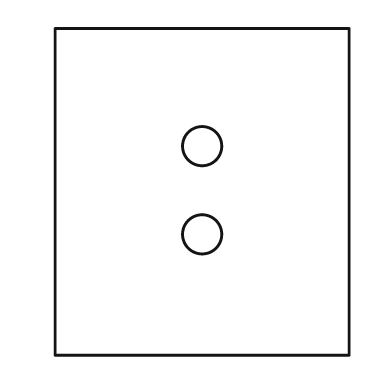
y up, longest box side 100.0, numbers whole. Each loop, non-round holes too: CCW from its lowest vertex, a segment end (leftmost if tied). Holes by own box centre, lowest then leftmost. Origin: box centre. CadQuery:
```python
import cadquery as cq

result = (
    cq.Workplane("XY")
    .moveTo(-45.0, -50.0)
    .lineTo(45.0, -50.0)
    .lineTo(45.0, 50.0)
    .lineTo(-45.0, 50.0)
    .close()
    .moveTo(0.0, -13.0)
    .circle(6.0)
    .moveTo(0.0, 14.0)
    .circle(6.0)
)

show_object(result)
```